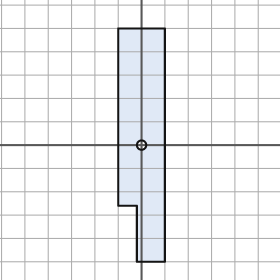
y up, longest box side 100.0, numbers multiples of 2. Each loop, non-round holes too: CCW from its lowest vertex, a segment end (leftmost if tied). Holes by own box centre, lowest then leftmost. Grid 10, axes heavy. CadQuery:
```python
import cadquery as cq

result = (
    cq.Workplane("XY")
    .moveTo(-2.0, -50.0)
    .lineTo(10.0, -50.0)
    .lineTo(10.0, 50.0)
    .lineTo(-10.0, 50.0)
    .lineTo(-10.0, -26.0)
    .lineTo(-2.0, -26.0)
    .close()
    .moveTo(0.0, 0.0)
    .circle(2.0)
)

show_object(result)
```